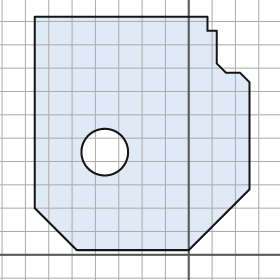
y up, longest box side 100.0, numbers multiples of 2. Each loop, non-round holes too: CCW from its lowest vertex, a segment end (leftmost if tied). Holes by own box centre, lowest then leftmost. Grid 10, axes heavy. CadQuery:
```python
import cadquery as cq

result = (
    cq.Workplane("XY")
    .moveTo(-48.0, 2.0)
    .lineTo(0.0, 2.0)
    .lineTo(26.0, 28.0)
    .lineTo(26.0, 74.0)
    .lineTo(22.0, 78.0)
    .lineTo(16.0, 78.0)
    .lineTo(12.0, 82.0)
    .lineTo(12.0, 96.0)
    .lineTo(8.0, 96.0)
    .lineTo(8.0, 102.0)
    .lineTo(-66.0, 102.0)
    .lineTo(-66.0, 20.0)
    .close()
    .moveTo(-36.0, 44.0)
    .circle(10.0)
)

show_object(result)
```